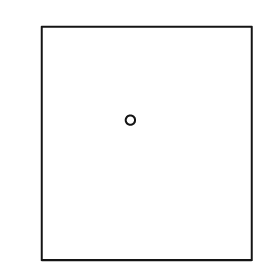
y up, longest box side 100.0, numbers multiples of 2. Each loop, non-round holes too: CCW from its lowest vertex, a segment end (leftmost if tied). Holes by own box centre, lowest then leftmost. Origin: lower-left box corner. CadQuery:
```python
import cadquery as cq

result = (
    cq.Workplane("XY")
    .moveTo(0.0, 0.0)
    .lineTo(90.0, 0.0)
    .lineTo(90.0, 100.0)
    .lineTo(0.0, 100.0)
    .close()
    .moveTo(38.0, 60.0)
    .circle(2.0)
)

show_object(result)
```